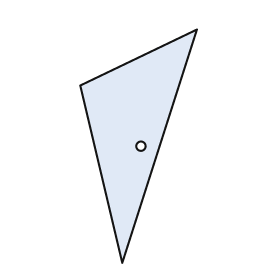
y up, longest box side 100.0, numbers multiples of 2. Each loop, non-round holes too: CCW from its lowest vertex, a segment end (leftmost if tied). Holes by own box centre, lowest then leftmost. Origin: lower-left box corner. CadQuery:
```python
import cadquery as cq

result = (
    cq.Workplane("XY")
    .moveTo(18.0, 0.0)
    .lineTo(50.0, 100.0)
    .lineTo(0.0, 76.0)
    .close()
    .moveTo(26.0, 50.0)
    .circle(2.0)
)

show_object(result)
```